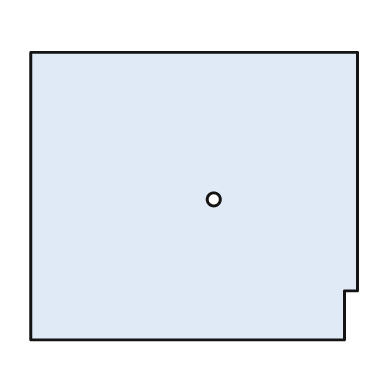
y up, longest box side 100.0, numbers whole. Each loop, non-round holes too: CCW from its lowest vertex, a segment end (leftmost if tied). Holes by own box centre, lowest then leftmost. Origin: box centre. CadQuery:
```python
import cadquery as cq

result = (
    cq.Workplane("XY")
    .moveTo(-50.0, -44.0)
    .lineTo(46.0, -44.0)
    .lineTo(46.0, -29.0)
    .lineTo(50.0, -29.0)
    .lineTo(50.0, 44.0)
    .lineTo(-50.0, 44.0)
    .close()
    .moveTo(6.0, -1.0)
    .circle(2.0)
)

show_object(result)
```